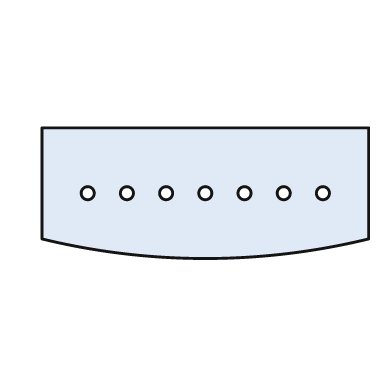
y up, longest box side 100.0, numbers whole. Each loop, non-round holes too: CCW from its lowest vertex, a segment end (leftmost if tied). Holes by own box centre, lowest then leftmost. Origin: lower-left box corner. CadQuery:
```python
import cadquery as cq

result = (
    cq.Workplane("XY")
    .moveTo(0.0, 6.0)
    .threePointArc((50.0, 0.0), (100.0, 6.0))
    .lineTo(100.0, 40.0)
    .lineTo(0.0, 40.0)
    .close()
    .moveTo(14.0, 20.0)
    .circle(2.0)
    .moveTo(26.0, 20.0)
    .circle(2.0)
    .moveTo(38.0, 20.0)
    .circle(2.0)
    .moveTo(50.0, 20.0)
    .circle(2.0)
    .moveTo(62.0, 20.0)
    .circle(2.0)
    .moveTo(74.0, 20.0)
    .circle(2.0)
    .moveTo(86.0, 20.0)
    .circle(2.0)
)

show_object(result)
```